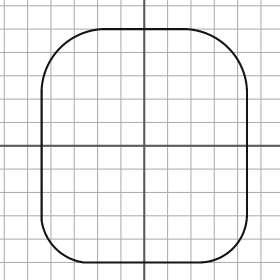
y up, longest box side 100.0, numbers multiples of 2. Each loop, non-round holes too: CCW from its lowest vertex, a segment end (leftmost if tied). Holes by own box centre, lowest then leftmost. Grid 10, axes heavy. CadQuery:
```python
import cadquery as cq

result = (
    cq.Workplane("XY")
    .moveTo(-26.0, -50.0)
    .lineTo(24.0, -50.0)
    .threePointArc((38.0, -44.0), (44.0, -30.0))
    .lineTo(44.0, 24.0)
    .threePointArc((36.0, 42.0), (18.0, 50.0))
    .lineTo(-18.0, 50.0)
    .threePointArc((-36.0, 42.0), (-44.0, 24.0))
    .lineTo(-44.0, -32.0)
    .threePointArc((-38.0, -44.0), (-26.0, -50.0))
    .close()
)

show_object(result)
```